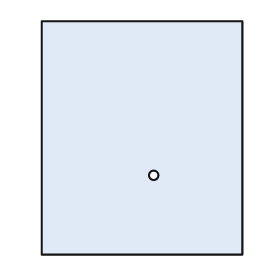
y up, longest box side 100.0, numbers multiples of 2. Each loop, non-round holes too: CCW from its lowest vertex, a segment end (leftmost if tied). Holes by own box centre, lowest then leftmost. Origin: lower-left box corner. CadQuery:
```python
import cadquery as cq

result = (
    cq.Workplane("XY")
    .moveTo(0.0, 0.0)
    .lineTo(86.0, 0.0)
    .lineTo(86.0, 100.0)
    .lineTo(0.0, 100.0)
    .close()
    .moveTo(48.0, 34.0)
    .circle(2.0)
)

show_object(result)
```